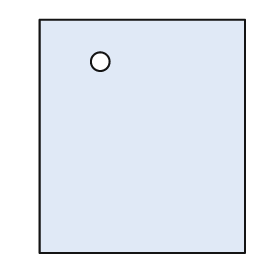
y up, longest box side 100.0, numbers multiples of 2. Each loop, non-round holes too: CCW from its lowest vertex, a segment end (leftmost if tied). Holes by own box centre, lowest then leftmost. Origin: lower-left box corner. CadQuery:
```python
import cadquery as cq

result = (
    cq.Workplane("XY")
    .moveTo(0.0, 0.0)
    .lineTo(88.0, 0.0)
    .lineTo(88.0, 100.0)
    .lineTo(0.0, 100.0)
    .close()
    .moveTo(26.0, 82.0)
    .circle(4.0)
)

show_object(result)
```